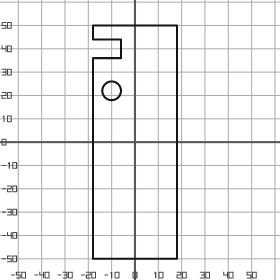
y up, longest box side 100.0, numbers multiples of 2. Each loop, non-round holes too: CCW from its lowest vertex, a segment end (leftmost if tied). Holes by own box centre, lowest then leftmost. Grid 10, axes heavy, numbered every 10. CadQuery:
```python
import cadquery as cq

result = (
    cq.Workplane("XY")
    .moveTo(-18.0, -50.0)
    .lineTo(18.0, -50.0)
    .lineTo(18.0, 50.0)
    .lineTo(-18.0, 50.0)
    .lineTo(-18.0, 44.0)
    .lineTo(-6.0, 44.0)
    .lineTo(-6.0, 36.0)
    .lineTo(-18.0, 36.0)
    .close()
    .moveTo(-10.0, 22.0)
    .circle(4.0)
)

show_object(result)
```